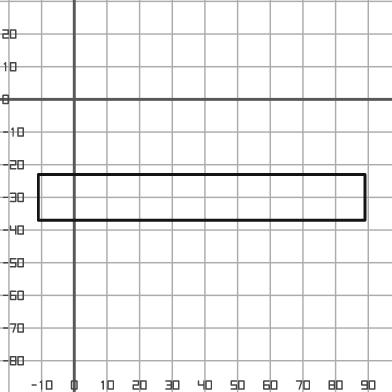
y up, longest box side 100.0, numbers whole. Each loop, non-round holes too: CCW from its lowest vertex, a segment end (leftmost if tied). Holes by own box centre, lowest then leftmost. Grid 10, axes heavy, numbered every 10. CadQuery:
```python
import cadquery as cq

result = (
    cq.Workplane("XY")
    .moveTo(-11.0, -37.0)
    .lineTo(89.0, -37.0)
    .lineTo(89.0, -23.0)
    .lineTo(-11.0, -23.0)
    .close()
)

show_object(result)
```